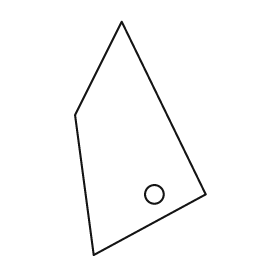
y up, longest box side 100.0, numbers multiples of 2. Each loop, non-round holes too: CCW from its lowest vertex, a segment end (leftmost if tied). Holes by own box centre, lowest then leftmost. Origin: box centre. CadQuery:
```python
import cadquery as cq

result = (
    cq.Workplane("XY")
    .moveTo(-20.0, -50.0)
    .lineTo(28.0, -24.0)
    .lineTo(-8.0, 50.0)
    .lineTo(-28.0, 10.0)
    .close()
    .moveTo(6.0, -24.0)
    .circle(4.0)
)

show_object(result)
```